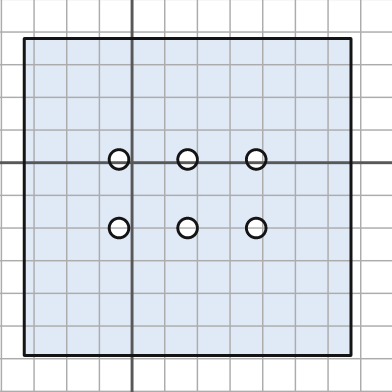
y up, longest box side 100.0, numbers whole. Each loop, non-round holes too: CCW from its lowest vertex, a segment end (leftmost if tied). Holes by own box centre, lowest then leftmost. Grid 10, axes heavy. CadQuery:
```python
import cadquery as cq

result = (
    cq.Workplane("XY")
    .moveTo(-33.0, -59.0)
    .lineTo(67.0, -59.0)
    .lineTo(67.0, 38.0)
    .lineTo(-33.0, 38.0)
    .close()
    .moveTo(-4.0, -20.0)
    .circle(3.0)
    .moveTo(17.0, -20.0)
    .circle(3.0)
    .moveTo(38.0, -20.0)
    .circle(3.0)
    .moveTo(-4.0, 1.0)
    .circle(3.0)
    .moveTo(17.0, 1.0)
    .circle(3.0)
    .moveTo(38.0, 1.0)
    .circle(3.0)
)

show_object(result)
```